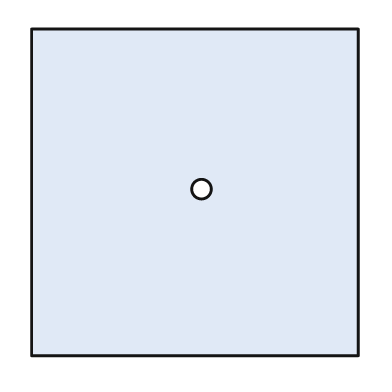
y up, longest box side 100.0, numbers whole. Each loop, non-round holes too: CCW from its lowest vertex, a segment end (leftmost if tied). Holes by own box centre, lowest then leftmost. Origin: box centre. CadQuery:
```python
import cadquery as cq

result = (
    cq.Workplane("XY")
    .moveTo(-50.0, -50.0)
    .lineTo(50.0, -50.0)
    .lineTo(50.0, 50.0)
    .lineTo(-50.0, 50.0)
    .close()
    .moveTo(2.0, 1.0)
    .circle(3.0)
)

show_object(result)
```